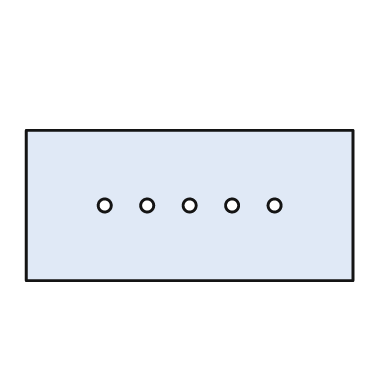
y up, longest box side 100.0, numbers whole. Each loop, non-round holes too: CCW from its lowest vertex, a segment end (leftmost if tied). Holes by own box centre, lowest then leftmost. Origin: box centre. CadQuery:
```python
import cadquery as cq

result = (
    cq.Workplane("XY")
    .moveTo(-50.0, -23.0)
    .lineTo(50.0, -23.0)
    .lineTo(50.0, 23.0)
    .lineTo(-50.0, 23.0)
    .close()
    .moveTo(-26.0, 0.0)
    .circle(2.0)
    .moveTo(-13.0, 0.0)
    .circle(2.0)
    .moveTo(0.0, 0.0)
    .circle(2.0)
    .moveTo(13.0, 0.0)
    .circle(2.0)
    .moveTo(26.0, 0.0)
    .circle(2.0)
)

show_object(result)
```